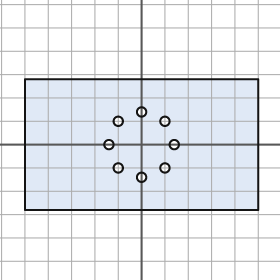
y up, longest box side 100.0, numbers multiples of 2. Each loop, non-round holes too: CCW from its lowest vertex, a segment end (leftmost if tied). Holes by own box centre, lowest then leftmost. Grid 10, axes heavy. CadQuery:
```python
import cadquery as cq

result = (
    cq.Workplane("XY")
    .moveTo(-50.0, -28.0)
    .lineTo(50.0, -28.0)
    .lineTo(50.0, 28.0)
    .lineTo(-50.0, 28.0)
    .close()
    .moveTo(0.0, -14.0)
    .circle(2.0)
    .moveTo(-10.0, -10.0)
    .circle(2.0)
    .moveTo(10.0, -10.0)
    .circle(2.0)
    .moveTo(-14.0, 0.0)
    .circle(2.0)
    .moveTo(14.0, 0.0)
    .circle(2.0)
    .moveTo(-10.0, 10.0)
    .circle(2.0)
    .moveTo(10.0, 10.0)
    .circle(2.0)
    .moveTo(0.0, 14.0)
    .circle(2.0)
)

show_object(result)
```